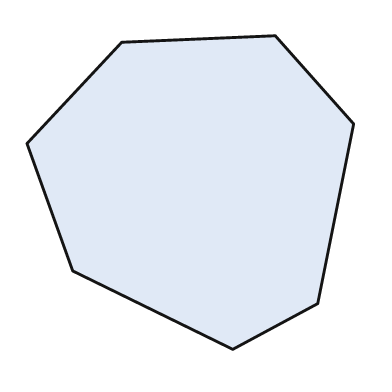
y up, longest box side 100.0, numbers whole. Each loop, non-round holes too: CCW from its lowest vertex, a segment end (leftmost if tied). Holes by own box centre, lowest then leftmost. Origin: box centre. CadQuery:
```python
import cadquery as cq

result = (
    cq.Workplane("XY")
    .moveTo(13.0, -48.0)
    .lineTo(39.0, -34.0)
    .lineTo(50.0, 21.0)
    .lineTo(26.0, 48.0)
    .lineTo(-21.0, 46.0)
    .lineTo(-50.0, 15.0)
    .lineTo(-36.0, -24.0)
    .close()
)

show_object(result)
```